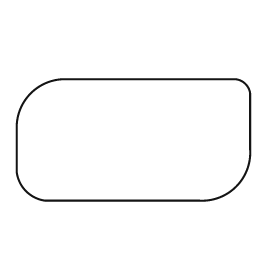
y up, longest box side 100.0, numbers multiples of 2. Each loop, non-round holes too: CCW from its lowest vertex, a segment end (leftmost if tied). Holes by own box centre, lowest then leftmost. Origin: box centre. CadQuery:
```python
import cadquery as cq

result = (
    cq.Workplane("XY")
    .moveTo(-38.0, -26.0)
    .lineTo(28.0, -26.0)
    .threePointArc((44.0, -20.0), (50.0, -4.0))
    .lineTo(50.0, 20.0)
    .threePointArc((48.0, 24.0), (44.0, 26.0))
    .lineTo(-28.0, 26.0)
    .threePointArc((-44.0, 20.0), (-50.0, 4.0))
    .lineTo(-50.0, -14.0)
    .threePointArc((-46.0, -22.0), (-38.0, -26.0))
    .close()
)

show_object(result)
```